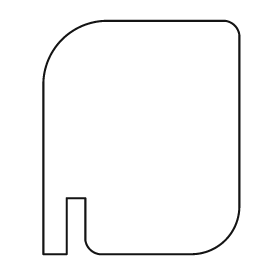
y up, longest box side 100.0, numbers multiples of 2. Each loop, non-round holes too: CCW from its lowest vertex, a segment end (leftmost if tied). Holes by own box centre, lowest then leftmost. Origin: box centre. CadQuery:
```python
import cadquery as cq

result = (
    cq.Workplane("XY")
    .moveTo(-42.0, -50.0)
    .lineTo(-32.0, -50.0)
    .lineTo(-32.0, -26.0)
    .lineTo(-24.0, -26.0)
    .lineTo(-24.0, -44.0)
    .threePointArc((-22.0, -48.0), (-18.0, -50.0))
    .lineTo(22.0, -50.0)
    .threePointArc((36.0, -44.0), (42.0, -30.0))
    .lineTo(42.0, 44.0)
    .threePointArc((40.0, 48.0), (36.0, 50.0))
    .lineTo(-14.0, 50.0)
    .threePointArc((-34.0, 42.0), (-42.0, 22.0))
    .close()
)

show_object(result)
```